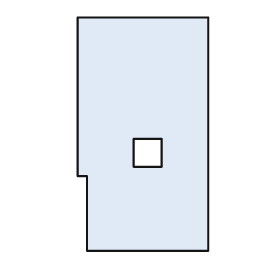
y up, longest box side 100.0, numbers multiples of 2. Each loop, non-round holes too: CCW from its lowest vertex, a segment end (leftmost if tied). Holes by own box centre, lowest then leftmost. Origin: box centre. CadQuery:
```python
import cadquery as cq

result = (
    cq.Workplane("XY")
    .moveTo(-24.0, -50.0)
    .lineTo(28.0, -50.0)
    .lineTo(28.0, 50.0)
    .lineTo(-28.0, 50.0)
    .lineTo(-28.0, -18.0)
    .lineTo(-24.0, -18.0)
    .close()
    .moveTo(-4.0, -14.0)
    .lineTo(8.0, -14.0)
    .lineTo(8.0, -2.0)
    .lineTo(-4.0, -2.0)
    .close()
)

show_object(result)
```